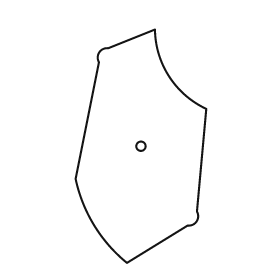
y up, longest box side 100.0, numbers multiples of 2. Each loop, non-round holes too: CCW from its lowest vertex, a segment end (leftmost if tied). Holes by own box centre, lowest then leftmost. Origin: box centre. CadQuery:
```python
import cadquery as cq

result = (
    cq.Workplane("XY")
    .moveTo(-6.0, -50.0)
    .lineTo(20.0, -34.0)
    .threePointArc((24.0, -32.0), (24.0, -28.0))
    .lineTo(28.0, 16.0)
    .threePointArc((12.0, 30.0), (6.0, 50.0))
    .lineTo(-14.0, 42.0)
    .threePointArc((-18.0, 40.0), (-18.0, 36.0))
    .lineTo(-28.0, -14.0)
    .threePointArc((-20.0, -34.0), (-6.0, -50.0))
    .close()
    .moveTo(0.0, 0.0)
    .circle(2.0)
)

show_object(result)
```